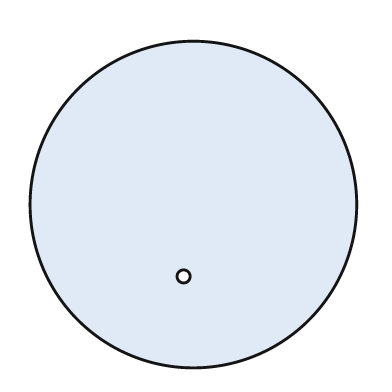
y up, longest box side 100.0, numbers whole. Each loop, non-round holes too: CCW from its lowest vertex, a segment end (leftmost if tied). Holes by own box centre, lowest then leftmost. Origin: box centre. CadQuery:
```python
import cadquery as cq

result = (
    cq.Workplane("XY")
    .moveTo(0.0, 0.0)
    .circle(50.0)
    .moveTo(-3.0, -22.0)
    .circle(2.0)
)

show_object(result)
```